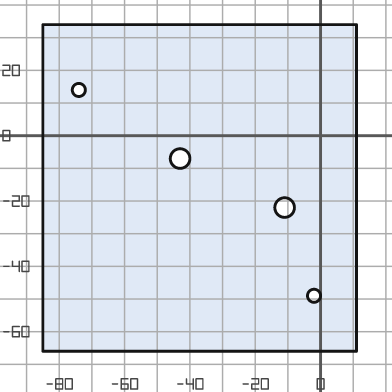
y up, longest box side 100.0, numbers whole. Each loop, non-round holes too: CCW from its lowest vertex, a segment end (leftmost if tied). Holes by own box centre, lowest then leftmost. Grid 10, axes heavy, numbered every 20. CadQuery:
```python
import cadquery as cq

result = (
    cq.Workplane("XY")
    .moveTo(-85.0, -66.0)
    .lineTo(11.0, -66.0)
    .lineTo(11.0, 34.0)
    .lineTo(-85.0, 34.0)
    .close()
    .moveTo(-2.0, -49.0)
    .circle(2.0)
    .moveTo(-11.0, -22.0)
    .circle(3.0)
    .moveTo(-43.0, -7.0)
    .circle(3.0)
    .moveTo(-74.0, 14.0)
    .circle(2.0)
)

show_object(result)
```